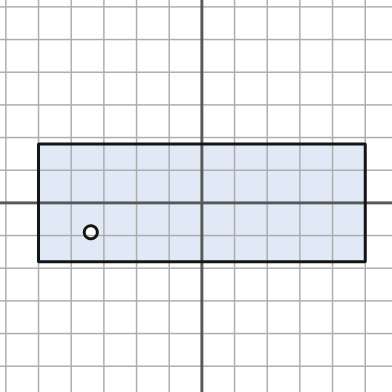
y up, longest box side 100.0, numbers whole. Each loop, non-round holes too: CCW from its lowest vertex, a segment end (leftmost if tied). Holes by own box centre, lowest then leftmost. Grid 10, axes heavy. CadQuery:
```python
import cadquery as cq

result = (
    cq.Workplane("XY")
    .moveTo(-50.0, -18.0)
    .lineTo(50.0, -18.0)
    .lineTo(50.0, 18.0)
    .lineTo(-50.0, 18.0)
    .close()
    .moveTo(-34.0, -9.0)
    .circle(2.0)
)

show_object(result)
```